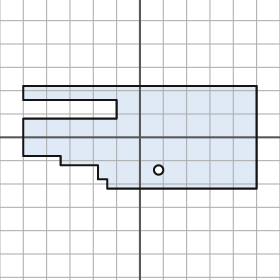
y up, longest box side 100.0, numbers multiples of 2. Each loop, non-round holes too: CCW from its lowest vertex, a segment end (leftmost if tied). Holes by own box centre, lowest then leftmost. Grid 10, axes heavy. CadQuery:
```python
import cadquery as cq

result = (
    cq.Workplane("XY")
    .moveTo(-14.0, -22.0)
    .lineTo(50.0, -22.0)
    .lineTo(50.0, 22.0)
    .lineTo(-50.0, 22.0)
    .lineTo(-50.0, 16.0)
    .lineTo(-10.0, 16.0)
    .lineTo(-10.0, 8.0)
    .lineTo(-50.0, 8.0)
    .lineTo(-50.0, -8.0)
    .lineTo(-34.0, -8.0)
    .lineTo(-34.0, -12.0)
    .lineTo(-18.0, -12.0)
    .lineTo(-18.0, -18.0)
    .lineTo(-14.0, -18.0)
    .close()
    .moveTo(8.0, -14.0)
    .circle(2.0)
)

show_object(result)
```